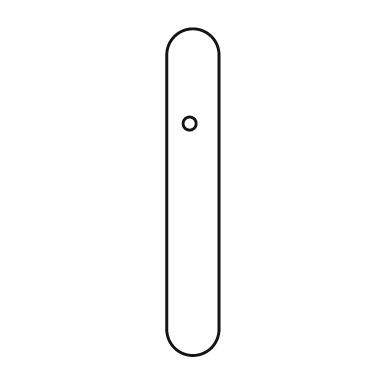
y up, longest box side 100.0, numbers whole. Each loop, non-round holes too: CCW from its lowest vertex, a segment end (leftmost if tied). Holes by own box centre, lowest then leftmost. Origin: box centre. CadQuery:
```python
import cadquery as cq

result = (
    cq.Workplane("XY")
    .moveTo(-8.0, -42.0)
    .threePointArc((0.0, -50.0), (8.0, -42.0))
    .lineTo(8.0, 42.0)
    .threePointArc((0.0, 50.0), (-8.0, 42.0))
    .close()
    .moveTo(-1.0, 21.0)
    .circle(2.0)
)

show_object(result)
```